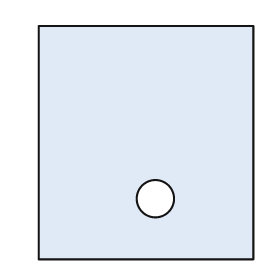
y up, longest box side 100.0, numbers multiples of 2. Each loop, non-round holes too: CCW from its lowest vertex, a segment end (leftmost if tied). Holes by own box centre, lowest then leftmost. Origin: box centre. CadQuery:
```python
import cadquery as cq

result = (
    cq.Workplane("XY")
    .moveTo(-46.0, -50.0)
    .lineTo(46.0, -50.0)
    .lineTo(46.0, 50.0)
    .lineTo(-46.0, 50.0)
    .close()
    .moveTo(4.0, -24.0)
    .circle(8.0)
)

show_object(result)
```